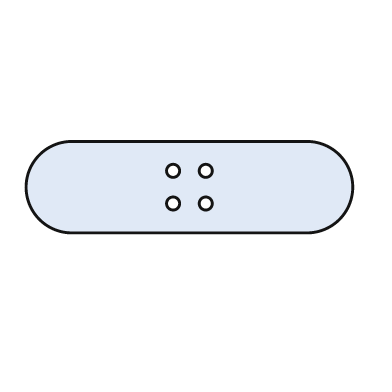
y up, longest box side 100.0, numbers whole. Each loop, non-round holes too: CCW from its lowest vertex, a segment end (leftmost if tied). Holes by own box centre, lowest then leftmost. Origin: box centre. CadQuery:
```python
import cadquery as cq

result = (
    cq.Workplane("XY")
    .moveTo(-36.0, -14.0)
    .lineTo(36.0, -14.0)
    .threePointArc((50.0, 0.0), (36.0, 14.0))
    .lineTo(-36.0, 14.0)
    .threePointArc((-50.0, 0.0), (-36.0, -14.0))
    .close()
    .moveTo(-5.0, -5.0)
    .circle(2.0)
    .moveTo(5.0, -5.0)
    .circle(2.0)
    .moveTo(-5.0, 5.0)
    .circle(2.0)
    .moveTo(5.0, 5.0)
    .circle(2.0)
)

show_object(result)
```